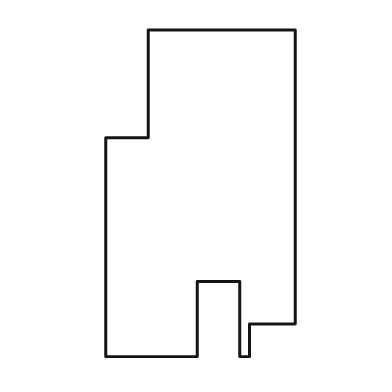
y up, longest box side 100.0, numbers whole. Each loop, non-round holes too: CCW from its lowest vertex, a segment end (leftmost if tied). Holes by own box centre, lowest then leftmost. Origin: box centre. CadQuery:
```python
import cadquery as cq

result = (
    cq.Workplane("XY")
    .moveTo(-29.0, -50.0)
    .lineTo(-1.0, -50.0)
    .lineTo(-1.0, -27.0)
    .lineTo(12.0, -27.0)
    .lineTo(12.0, -50.0)
    .lineTo(15.0, -50.0)
    .lineTo(15.0, -40.0)
    .lineTo(29.0, -40.0)
    .lineTo(29.0, 50.0)
    .lineTo(-16.0, 50.0)
    .lineTo(-16.0, 17.0)
    .lineTo(-29.0, 17.0)
    .close()
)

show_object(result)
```